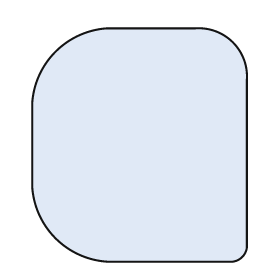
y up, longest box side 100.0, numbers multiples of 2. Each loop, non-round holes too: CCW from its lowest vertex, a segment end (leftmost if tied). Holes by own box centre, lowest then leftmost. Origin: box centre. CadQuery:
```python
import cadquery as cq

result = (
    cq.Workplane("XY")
    .moveTo(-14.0, -50.0)
    .lineTo(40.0, -50.0)
    .threePointArc((44.0, -48.0), (46.0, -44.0))
    .lineTo(46.0, 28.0)
    .threePointArc((40.0, 44.0), (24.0, 50.0))
    .lineTo(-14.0, 50.0)
    .threePointArc((-36.0, 40.0), (-46.0, 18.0))
    .lineTo(-46.0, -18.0)
    .threePointArc((-36.0, -40.0), (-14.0, -50.0))
    .close()
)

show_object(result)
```